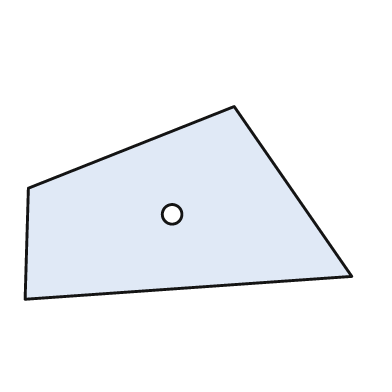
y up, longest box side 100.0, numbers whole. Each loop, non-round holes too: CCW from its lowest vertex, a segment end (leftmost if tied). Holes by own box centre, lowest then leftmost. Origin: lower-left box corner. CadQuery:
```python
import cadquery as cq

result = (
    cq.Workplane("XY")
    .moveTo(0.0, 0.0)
    .lineTo(100.0, 7.0)
    .lineTo(64.0, 59.0)
    .lineTo(1.0, 34.0)
    .close()
    .moveTo(45.0, 26.0)
    .circle(3.0)
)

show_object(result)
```